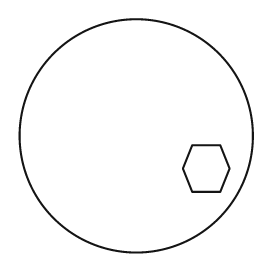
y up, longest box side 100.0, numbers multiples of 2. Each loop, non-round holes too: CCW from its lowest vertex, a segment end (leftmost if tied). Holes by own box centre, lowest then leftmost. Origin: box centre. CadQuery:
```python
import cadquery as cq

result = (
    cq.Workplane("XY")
    .moveTo(0.0, 0.0)
    .circle(50.0)
    .moveTo(24.0, -24.0)
    .lineTo(36.0, -24.0)
    .lineTo(40.0, -14.0)
    .lineTo(36.0, -4.0)
    .lineTo(24.0, -4.0)
    .lineTo(20.0, -14.0)
    .close()
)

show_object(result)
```